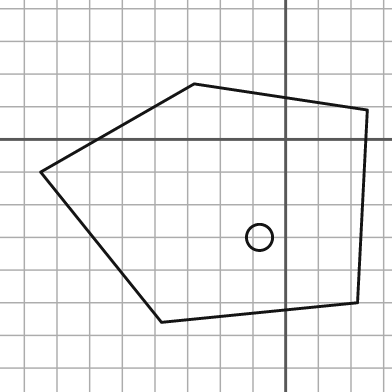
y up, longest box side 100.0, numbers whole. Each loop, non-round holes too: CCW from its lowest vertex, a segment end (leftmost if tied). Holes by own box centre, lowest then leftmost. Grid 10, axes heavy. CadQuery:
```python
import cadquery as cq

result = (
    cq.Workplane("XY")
    .moveTo(-38.0, -56.0)
    .lineTo(22.0, -50.0)
    .lineTo(25.0, 9.0)
    .lineTo(-28.0, 17.0)
    .lineTo(-75.0, -10.0)
    .close()
    .moveTo(-8.0, -30.0)
    .circle(4.0)
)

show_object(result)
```